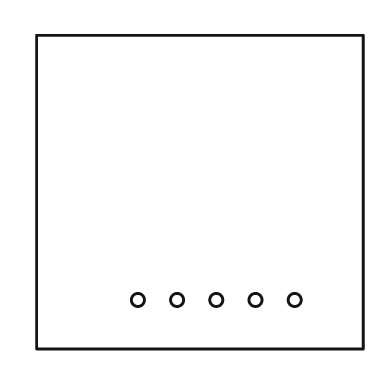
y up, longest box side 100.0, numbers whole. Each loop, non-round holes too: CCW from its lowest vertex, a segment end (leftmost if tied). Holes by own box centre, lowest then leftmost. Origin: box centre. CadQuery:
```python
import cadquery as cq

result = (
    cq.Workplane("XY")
    .moveTo(-50.0, -48.0)
    .lineTo(50.0, -48.0)
    .lineTo(50.0, 48.0)
    .lineTo(-50.0, 48.0)
    .close()
    .moveTo(-19.0, -33.0)
    .circle(2.0)
    .moveTo(-7.0, -33.0)
    .circle(2.0)
    .moveTo(5.0, -33.0)
    .circle(2.0)
    .moveTo(17.0, -33.0)
    .circle(2.0)
    .moveTo(29.0, -33.0)
    .circle(2.0)
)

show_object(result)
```